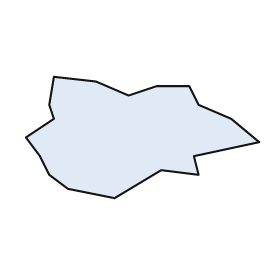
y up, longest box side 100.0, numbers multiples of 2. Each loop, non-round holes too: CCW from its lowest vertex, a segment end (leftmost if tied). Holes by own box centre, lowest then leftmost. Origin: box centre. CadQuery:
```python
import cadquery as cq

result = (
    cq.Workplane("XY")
    .moveTo(-12.0, -26.0)
    .lineTo(8.0, -14.0)
    .lineTo(24.0, -16.0)
    .lineTo(22.0, -8.0)
    .lineTo(50.0, -2.0)
    .lineTo(38.0, 8.0)
    .lineTo(24.0, 14.0)
    .lineTo(20.0, 22.0)
    .lineTo(6.0, 22.0)
    .lineTo(-6.0, 18.0)
    .lineTo(-20.0, 24.0)
    .lineTo(-38.0, 26.0)
    .lineTo(-40.0, 14.0)
    .lineTo(-38.0, 8.0)
    .lineTo(-50.0, 0.0)
    .lineTo(-44.0, -8.0)
    .lineTo(-40.0, -16.0)
    .lineTo(-32.0, -22.0)
    .close()
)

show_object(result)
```